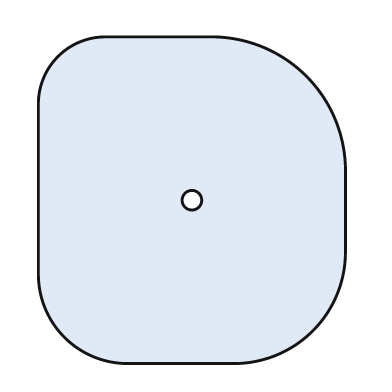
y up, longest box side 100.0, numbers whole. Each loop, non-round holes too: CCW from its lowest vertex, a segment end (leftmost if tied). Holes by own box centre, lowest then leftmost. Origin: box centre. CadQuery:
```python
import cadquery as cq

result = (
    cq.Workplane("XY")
    .moveTo(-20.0, -50.0)
    .lineTo(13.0, -50.0)
    .threePointArc((37.0, -40.0), (47.0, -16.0))
    .lineTo(47.0, 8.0)
    .threePointArc((35.0, 38.0), (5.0, 50.0))
    .lineTo(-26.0, 50.0)
    .threePointArc((-41.0, 44.0), (-47.0, 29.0))
    .lineTo(-47.0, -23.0)
    .threePointArc((-39.0, -42.0), (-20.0, -50.0))
    .close()
    .moveTo(0.0, 0.0)
    .circle(3.0)
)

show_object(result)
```